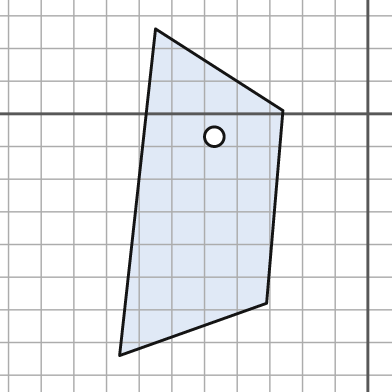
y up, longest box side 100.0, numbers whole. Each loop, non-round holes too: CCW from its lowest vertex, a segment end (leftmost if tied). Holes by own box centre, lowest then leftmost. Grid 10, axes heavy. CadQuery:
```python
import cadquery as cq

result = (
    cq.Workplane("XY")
    .moveTo(-76.0, -74.0)
    .lineTo(-31.0, -58.0)
    .lineTo(-26.0, 1.0)
    .lineTo(-65.0, 26.0)
    .close()
    .moveTo(-47.0, -7.0)
    .circle(3.0)
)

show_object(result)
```